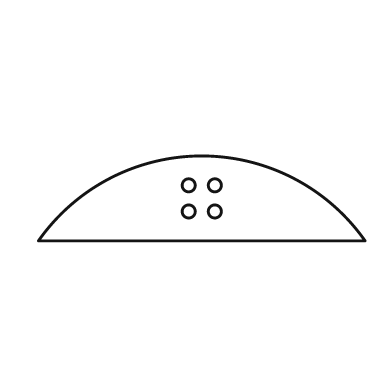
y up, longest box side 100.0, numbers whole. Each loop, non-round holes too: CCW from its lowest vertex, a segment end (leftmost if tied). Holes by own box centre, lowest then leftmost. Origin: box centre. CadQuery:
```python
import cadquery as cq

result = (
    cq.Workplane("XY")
    .moveTo(-50.0, -13.0)
    .lineTo(50.0, -13.0)
    .threePointArc((0.0, 13.0), (-50.0, -13.0))
    .close()
    .moveTo(-4.0, -4.0)
    .circle(2.0)
    .moveTo(4.0, -4.0)
    .circle(2.0)
    .moveTo(-4.0, 4.0)
    .circle(2.0)
    .moveTo(4.0, 4.0)
    .circle(2.0)
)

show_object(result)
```